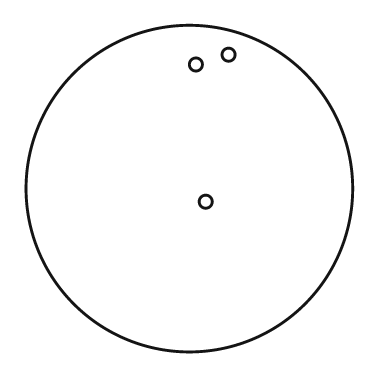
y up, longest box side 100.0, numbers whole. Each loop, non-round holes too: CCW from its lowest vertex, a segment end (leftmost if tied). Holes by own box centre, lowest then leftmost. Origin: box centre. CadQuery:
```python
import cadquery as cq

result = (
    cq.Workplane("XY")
    .moveTo(0.0, 0.0)
    .circle(50.0)
    .moveTo(5.0, -4.0)
    .circle(2.0)
    .moveTo(2.0, 38.0)
    .circle(2.0)
    .moveTo(12.0, 41.0)
    .circle(2.0)
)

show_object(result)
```